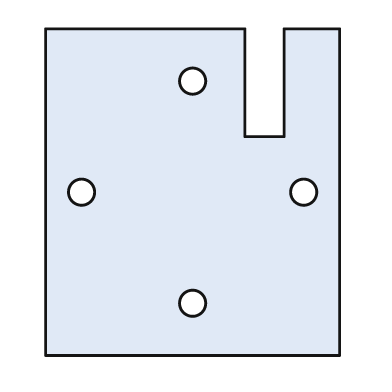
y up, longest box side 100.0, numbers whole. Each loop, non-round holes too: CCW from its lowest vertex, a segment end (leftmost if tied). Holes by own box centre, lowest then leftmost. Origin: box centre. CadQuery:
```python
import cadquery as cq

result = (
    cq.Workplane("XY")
    .moveTo(-45.0, -50.0)
    .lineTo(45.0, -50.0)
    .lineTo(45.0, 50.0)
    .lineTo(28.0, 50.0)
    .lineTo(28.0, 17.0)
    .lineTo(16.0, 17.0)
    .lineTo(16.0, 50.0)
    .lineTo(-45.0, 50.0)
    .close()
    .moveTo(0.0, -34.0)
    .circle(4.0)
    .moveTo(-34.0, 0.0)
    .circle(4.0)
    .moveTo(34.0, 0.0)
    .circle(4.0)
    .moveTo(0.0, 34.0)
    .circle(4.0)
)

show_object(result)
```